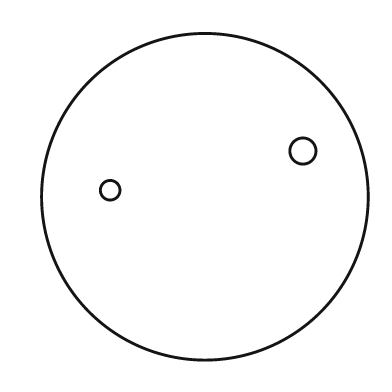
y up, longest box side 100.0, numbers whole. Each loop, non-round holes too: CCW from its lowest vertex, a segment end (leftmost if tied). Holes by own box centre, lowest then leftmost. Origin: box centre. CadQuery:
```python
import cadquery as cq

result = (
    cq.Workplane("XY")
    .moveTo(0.0, 0.0)
    .circle(50.0)
    .moveTo(-29.0, 2.0)
    .circle(3.0)
    .moveTo(30.0, 14.0)
    .circle(4.0)
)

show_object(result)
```